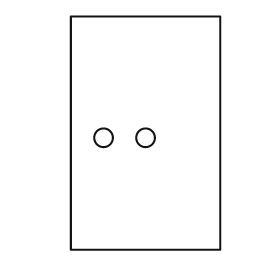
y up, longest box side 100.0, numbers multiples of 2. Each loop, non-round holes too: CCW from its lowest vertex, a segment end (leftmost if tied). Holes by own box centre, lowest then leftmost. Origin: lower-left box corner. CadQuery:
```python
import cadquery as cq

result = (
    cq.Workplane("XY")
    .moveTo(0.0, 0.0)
    .lineTo(64.0, 0.0)
    .lineTo(64.0, 100.0)
    .lineTo(0.0, 100.0)
    .close()
    .moveTo(14.0, 48.0)
    .circle(4.0)
    .moveTo(32.0, 48.0)
    .circle(4.0)
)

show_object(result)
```